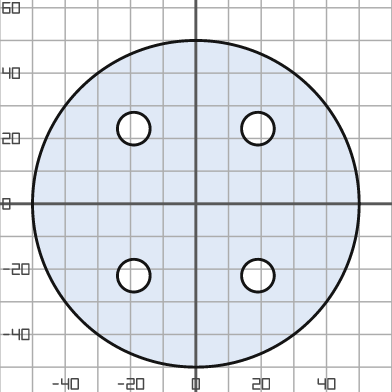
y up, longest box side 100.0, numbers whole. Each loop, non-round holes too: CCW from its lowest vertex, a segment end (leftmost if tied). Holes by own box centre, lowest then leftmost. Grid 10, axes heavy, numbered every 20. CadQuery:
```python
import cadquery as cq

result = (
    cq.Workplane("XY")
    .moveTo(0.0, 0.0)
    .circle(50.0)
    .moveTo(-19.0, -22.0)
    .circle(5.0)
    .moveTo(19.0, -22.0)
    .circle(5.0)
    .moveTo(-19.0, 23.0)
    .circle(5.0)
    .moveTo(19.0, 23.0)
    .circle(5.0)
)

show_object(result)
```